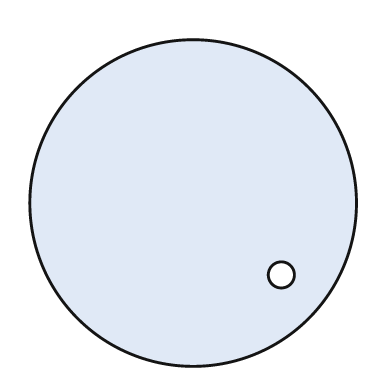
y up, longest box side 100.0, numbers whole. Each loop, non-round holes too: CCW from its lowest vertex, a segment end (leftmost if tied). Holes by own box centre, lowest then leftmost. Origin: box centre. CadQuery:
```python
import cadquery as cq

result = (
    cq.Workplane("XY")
    .moveTo(0.0, 0.0)
    .circle(50.0)
    .moveTo(27.0, -22.0)
    .circle(4.0)
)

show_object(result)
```